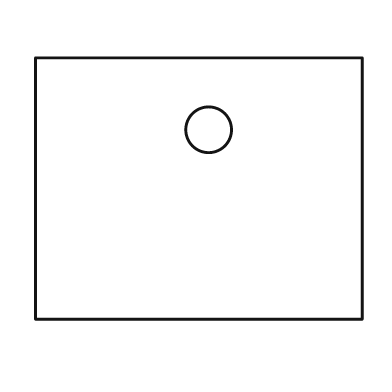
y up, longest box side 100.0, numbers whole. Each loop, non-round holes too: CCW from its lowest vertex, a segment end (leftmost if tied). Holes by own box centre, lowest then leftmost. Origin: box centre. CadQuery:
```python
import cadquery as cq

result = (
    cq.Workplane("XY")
    .moveTo(-50.0, -40.0)
    .lineTo(50.0, -40.0)
    .lineTo(50.0, 40.0)
    .lineTo(-50.0, 40.0)
    .close()
    .moveTo(3.0, 18.0)
    .circle(7.0)
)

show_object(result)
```